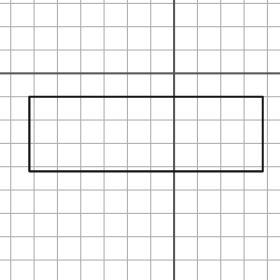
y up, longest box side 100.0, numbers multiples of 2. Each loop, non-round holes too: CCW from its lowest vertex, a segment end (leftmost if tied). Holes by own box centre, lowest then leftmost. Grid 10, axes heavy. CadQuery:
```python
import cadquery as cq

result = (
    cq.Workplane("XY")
    .moveTo(-62.0, -42.0)
    .lineTo(38.0, -42.0)
    .lineTo(38.0, -10.0)
    .lineTo(-62.0, -10.0)
    .close()
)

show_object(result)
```